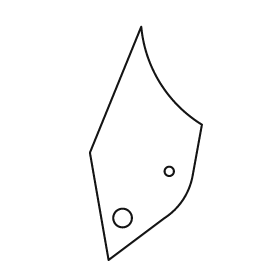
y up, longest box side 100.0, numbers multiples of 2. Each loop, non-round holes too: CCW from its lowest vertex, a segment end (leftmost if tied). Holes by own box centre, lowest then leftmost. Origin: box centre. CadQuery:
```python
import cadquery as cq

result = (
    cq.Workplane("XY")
    .moveTo(-16.0, -50.0)
    .lineTo(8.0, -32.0)
    .threePointArc((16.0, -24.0), (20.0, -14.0))
    .lineTo(24.0, 8.0)
    .threePointArc((6.0, 26.0), (-2.0, 50.0))
    .lineTo(-24.0, -4.0)
    .close()
    .moveTo(-10.0, -32.0)
    .circle(4.0)
    .moveTo(10.0, -12.0)
    .circle(2.0)
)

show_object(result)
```